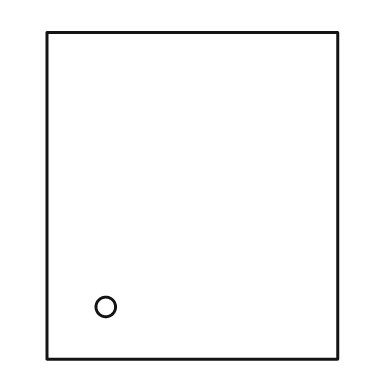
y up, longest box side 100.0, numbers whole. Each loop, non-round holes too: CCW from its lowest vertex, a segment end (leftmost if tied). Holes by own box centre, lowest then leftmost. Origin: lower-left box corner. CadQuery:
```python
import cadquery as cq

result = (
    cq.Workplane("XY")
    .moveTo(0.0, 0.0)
    .lineTo(89.0, 0.0)
    .lineTo(89.0, 100.0)
    .lineTo(0.0, 100.0)
    .close()
    .moveTo(18.0, 16.0)
    .circle(3.0)
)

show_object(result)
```